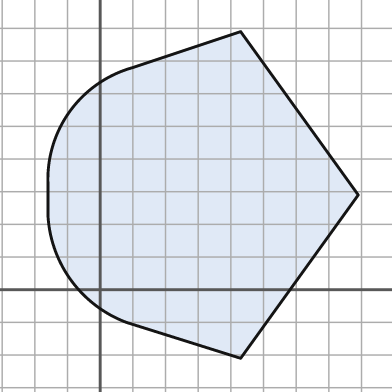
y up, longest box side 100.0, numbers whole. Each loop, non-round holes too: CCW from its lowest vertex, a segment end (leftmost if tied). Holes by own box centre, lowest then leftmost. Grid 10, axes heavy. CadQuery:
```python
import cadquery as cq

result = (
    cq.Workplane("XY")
    .moveTo(43.0, -21.0)
    .lineTo(79.0, 29.0)
    .lineTo(43.0, 79.0)
    .lineTo(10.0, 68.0)
    .threePointArc((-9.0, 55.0), (-16.0, 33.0))
    .lineTo(-16.0, 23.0)
    .threePointArc((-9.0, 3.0), (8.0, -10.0))
    .close()
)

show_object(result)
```